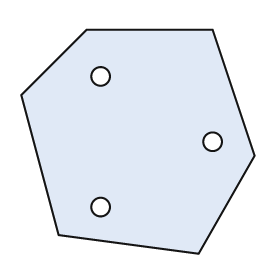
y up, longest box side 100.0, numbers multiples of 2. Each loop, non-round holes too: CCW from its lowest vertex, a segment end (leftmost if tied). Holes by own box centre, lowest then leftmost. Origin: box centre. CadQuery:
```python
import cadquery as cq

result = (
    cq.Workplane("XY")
    .moveTo(26.0, -48.0)
    .lineTo(50.0, -6.0)
    .lineTo(32.0, 48.0)
    .lineTo(-22.0, 48.0)
    .lineTo(-50.0, 20.0)
    .lineTo(-34.0, -40.0)
    .close()
    .moveTo(-16.0, -28.0)
    .circle(4.0)
    .moveTo(32.0, 0.0)
    .circle(4.0)
    .moveTo(-16.0, 28.0)
    .circle(4.0)
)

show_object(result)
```